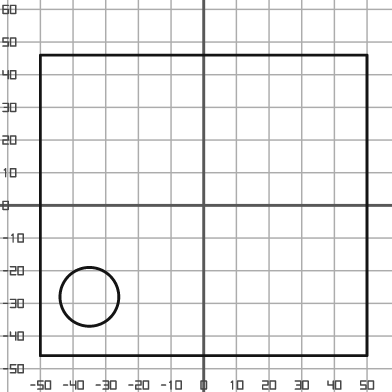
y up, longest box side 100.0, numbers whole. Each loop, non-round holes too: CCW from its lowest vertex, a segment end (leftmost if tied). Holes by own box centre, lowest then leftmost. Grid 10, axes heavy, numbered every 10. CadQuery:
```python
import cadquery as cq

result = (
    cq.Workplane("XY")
    .moveTo(-50.0, -46.0)
    .lineTo(50.0, -46.0)
    .lineTo(50.0, 46.0)
    .lineTo(-50.0, 46.0)
    .close()
    .moveTo(-35.0, -28.0)
    .circle(9.0)
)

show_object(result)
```